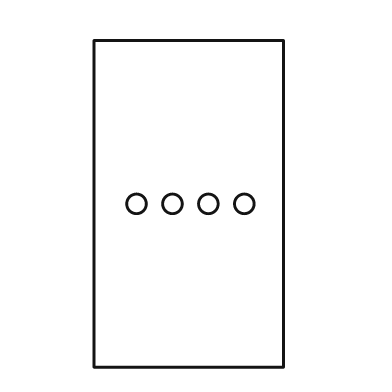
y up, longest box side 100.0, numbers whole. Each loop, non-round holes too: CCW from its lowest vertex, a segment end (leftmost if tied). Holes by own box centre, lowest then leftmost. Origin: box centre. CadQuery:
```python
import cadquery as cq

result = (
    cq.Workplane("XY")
    .moveTo(-29.0, -50.0)
    .lineTo(29.0, -50.0)
    .lineTo(29.0, 50.0)
    .lineTo(-29.0, 50.0)
    .close()
    .moveTo(-16.0, 0.0)
    .circle(3.0)
    .moveTo(-5.0, 0.0)
    .circle(3.0)
    .moveTo(6.0, 0.0)
    .circle(3.0)
    .moveTo(17.0, 0.0)
    .circle(3.0)
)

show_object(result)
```